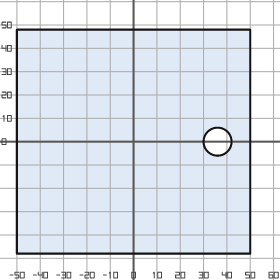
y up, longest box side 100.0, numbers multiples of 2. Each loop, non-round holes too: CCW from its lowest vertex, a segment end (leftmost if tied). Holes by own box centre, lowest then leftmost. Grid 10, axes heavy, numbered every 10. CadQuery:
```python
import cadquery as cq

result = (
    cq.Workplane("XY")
    .moveTo(-50.0, -48.0)
    .lineTo(50.0, -48.0)
    .lineTo(50.0, 48.0)
    .lineTo(-50.0, 48.0)
    .close()
    .moveTo(36.0, 0.0)
    .circle(6.0)
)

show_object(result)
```